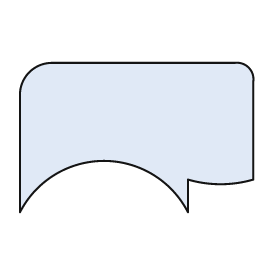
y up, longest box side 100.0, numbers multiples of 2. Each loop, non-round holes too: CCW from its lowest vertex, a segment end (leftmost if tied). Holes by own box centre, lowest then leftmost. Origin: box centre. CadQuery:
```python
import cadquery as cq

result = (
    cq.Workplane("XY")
    .moveTo(-50.0, -32.0)
    .threePointArc((-14.0, -10.0), (22.0, -32.0))
    .lineTo(22.0, -18.0)
    .threePointArc((36.0, -20.0), (50.0, -18.0))
    .lineTo(50.0, 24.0)
    .threePointArc((48.0, 30.0), (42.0, 32.0))
    .lineTo(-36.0, 32.0)
    .threePointArc((-46.0, 28.0), (-50.0, 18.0))
    .close()
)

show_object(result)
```